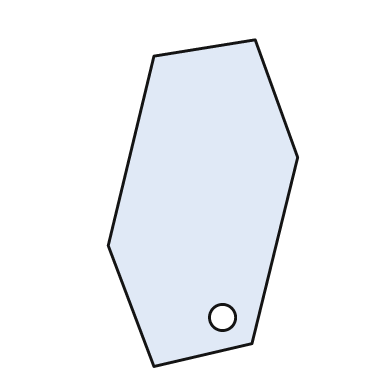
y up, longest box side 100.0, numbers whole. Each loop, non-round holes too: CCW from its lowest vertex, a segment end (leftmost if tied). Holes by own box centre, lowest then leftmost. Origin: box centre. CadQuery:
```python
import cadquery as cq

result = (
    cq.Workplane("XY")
    .moveTo(-15.0, -50.0)
    .lineTo(15.0, -43.0)
    .lineTo(29.0, 14.0)
    .lineTo(16.0, 50.0)
    .lineTo(-15.0, 45.0)
    .lineTo(-29.0, -13.0)
    .close()
    .moveTo(6.0, -35.0)
    .circle(4.0)
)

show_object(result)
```